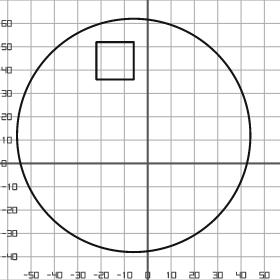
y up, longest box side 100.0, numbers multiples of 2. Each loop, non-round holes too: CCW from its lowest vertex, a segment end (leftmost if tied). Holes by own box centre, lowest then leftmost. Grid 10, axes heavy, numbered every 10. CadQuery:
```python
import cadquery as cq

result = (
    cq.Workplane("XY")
    .moveTo(-6.0, 12.0)
    .circle(50.0)
    .moveTo(-22.0, 36.0)
    .lineTo(-6.0, 36.0)
    .lineTo(-6.0, 52.0)
    .lineTo(-22.0, 52.0)
    .close()
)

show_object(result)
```